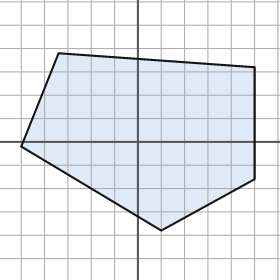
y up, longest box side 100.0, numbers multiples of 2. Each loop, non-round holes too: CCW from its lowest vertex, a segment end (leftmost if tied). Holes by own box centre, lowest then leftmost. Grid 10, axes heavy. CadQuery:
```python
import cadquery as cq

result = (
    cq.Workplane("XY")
    .moveTo(10.0, -38.0)
    .lineTo(50.0, -16.0)
    .lineTo(50.0, 32.0)
    .lineTo(-34.0, 38.0)
    .lineTo(-50.0, -2.0)
    .close()
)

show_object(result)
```